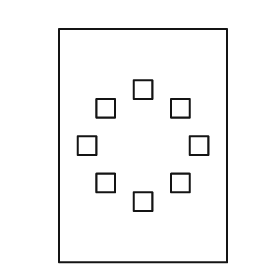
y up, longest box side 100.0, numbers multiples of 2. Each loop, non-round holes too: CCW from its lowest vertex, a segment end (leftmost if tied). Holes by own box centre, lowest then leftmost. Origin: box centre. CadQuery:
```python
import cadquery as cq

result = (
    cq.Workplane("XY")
    .moveTo(-36.0, -50.0)
    .lineTo(36.0, -50.0)
    .lineTo(36.0, 50.0)
    .lineTo(-36.0, 50.0)
    .close()
    .moveTo(-4.0, -28.0)
    .lineTo(4.0, -28.0)
    .lineTo(4.0, -20.0)
    .lineTo(-4.0, -20.0)
    .close()
    .moveTo(-20.0, -20.0)
    .lineTo(-12.0, -20.0)
    .lineTo(-12.0, -12.0)
    .lineTo(-20.0, -12.0)
    .close()
    .moveTo(12.0, -20.0)
    .lineTo(20.0, -20.0)
    .lineTo(20.0, -12.0)
    .lineTo(12.0, -12.0)
    .close()
    .moveTo(-28.0, -4.0)
    .lineTo(-20.0, -4.0)
    .lineTo(-20.0, 4.0)
    .lineTo(-28.0, 4.0)
    .close()
    .moveTo(20.0, -4.0)
    .lineTo(28.0, -4.0)
    .lineTo(28.0, 4.0)
    .lineTo(20.0, 4.0)
    .close()
    .moveTo(-20.0, 12.0)
    .lineTo(-12.0, 12.0)
    .lineTo(-12.0, 20.0)
    .lineTo(-20.0, 20.0)
    .close()
    .moveTo(12.0, 12.0)
    .lineTo(20.0, 12.0)
    .lineTo(20.0, 20.0)
    .lineTo(12.0, 20.0)
    .close()
    .moveTo(-4.0, 20.0)
    .lineTo(4.0, 20.0)
    .lineTo(4.0, 28.0)
    .lineTo(-4.0, 28.0)
    .close()
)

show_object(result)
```